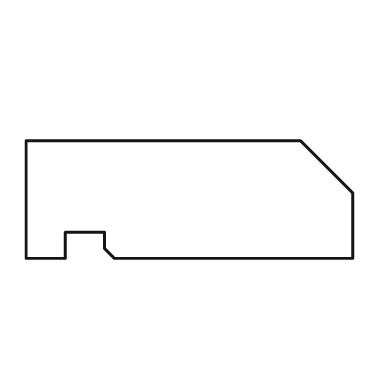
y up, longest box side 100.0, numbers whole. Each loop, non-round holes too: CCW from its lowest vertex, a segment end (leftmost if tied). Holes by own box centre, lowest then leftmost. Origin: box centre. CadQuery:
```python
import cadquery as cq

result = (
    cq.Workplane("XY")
    .moveTo(-50.0, -18.0)
    .lineTo(-38.0, -18.0)
    .lineTo(-38.0, -10.0)
    .lineTo(-26.0, -10.0)
    .lineTo(-26.0, -15.0)
    .lineTo(-23.0, -18.0)
    .lineTo(50.0, -18.0)
    .lineTo(50.0, 2.0)
    .lineTo(34.0, 18.0)
    .lineTo(-50.0, 18.0)
    .close()
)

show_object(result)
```